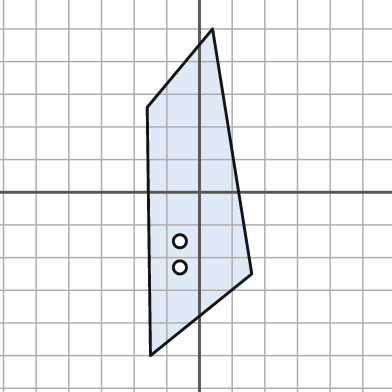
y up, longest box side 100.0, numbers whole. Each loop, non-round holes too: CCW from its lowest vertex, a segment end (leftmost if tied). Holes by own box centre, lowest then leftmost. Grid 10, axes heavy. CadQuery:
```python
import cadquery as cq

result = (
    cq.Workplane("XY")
    .moveTo(-15.0, -50.0)
    .lineTo(16.0, -25.0)
    .lineTo(4.0, 50.0)
    .lineTo(-16.0, 26.0)
    .close()
    .moveTo(-6.0, -23.0)
    .circle(2.0)
    .moveTo(-6.0, -15.0)
    .circle(2.0)
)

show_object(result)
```